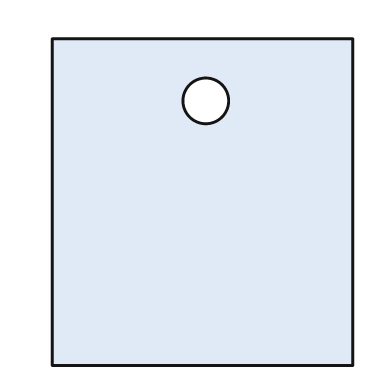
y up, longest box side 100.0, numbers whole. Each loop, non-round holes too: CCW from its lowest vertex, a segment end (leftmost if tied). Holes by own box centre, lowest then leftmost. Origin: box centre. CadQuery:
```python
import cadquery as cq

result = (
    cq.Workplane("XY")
    .moveTo(-46.0, -50.0)
    .lineTo(46.0, -50.0)
    .lineTo(46.0, 50.0)
    .lineTo(-46.0, 50.0)
    .close()
    .moveTo(1.0, 31.0)
    .circle(7.0)
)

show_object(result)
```